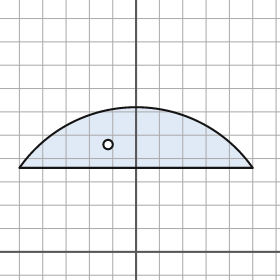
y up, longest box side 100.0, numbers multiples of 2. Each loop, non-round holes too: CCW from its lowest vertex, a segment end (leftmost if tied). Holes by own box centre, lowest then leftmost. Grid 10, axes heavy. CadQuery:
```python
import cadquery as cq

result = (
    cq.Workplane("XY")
    .moveTo(-50.0, 36.0)
    .lineTo(50.0, 36.0)
    .threePointArc((0.0, 62.0), (-50.0, 36.0))
    .close()
    .moveTo(-12.0, 46.0)
    .circle(2.0)
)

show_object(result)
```